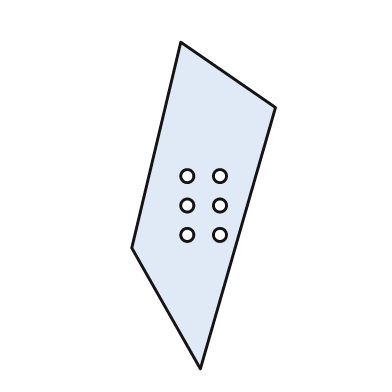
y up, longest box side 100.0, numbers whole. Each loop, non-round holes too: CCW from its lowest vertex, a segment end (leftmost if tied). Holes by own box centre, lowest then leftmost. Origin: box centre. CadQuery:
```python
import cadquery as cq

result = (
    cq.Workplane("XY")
    .moveTo(-1.0, -50.0)
    .lineTo(22.0, 30.0)
    .lineTo(-7.0, 50.0)
    .lineTo(-22.0, -13.0)
    .close()
    .moveTo(-5.0, -9.0)
    .circle(2.0)
    .moveTo(5.0, -9.0)
    .circle(2.0)
    .moveTo(-5.0, 0.0)
    .circle(2.0)
    .moveTo(5.0, 0.0)
    .circle(2.0)
    .moveTo(-5.0, 9.0)
    .circle(2.0)
    .moveTo(5.0, 9.0)
    .circle(2.0)
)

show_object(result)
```